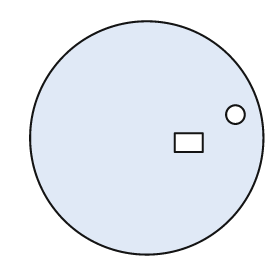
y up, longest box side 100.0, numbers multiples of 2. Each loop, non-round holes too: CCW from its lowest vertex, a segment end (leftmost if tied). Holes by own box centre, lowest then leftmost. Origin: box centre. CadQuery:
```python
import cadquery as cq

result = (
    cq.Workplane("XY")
    .moveTo(0.0, 0.0)
    .circle(50.0)
    .moveTo(12.0, -6.0)
    .lineTo(24.0, -6.0)
    .lineTo(24.0, 2.0)
    .lineTo(12.0, 2.0)
    .close()
    .moveTo(38.0, 10.0)
    .circle(4.0)
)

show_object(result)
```